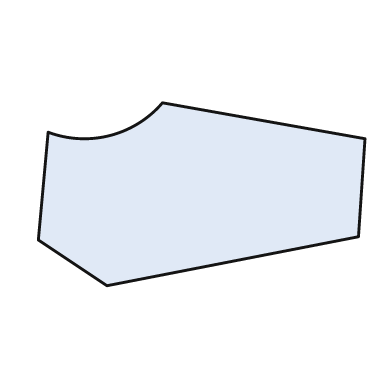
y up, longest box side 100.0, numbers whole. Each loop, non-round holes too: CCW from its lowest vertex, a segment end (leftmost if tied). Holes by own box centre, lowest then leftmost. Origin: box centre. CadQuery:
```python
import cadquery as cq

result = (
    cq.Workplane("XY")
    .moveTo(-29.0, -28.0)
    .lineTo(48.0, -13.0)
    .lineTo(50.0, 17.0)
    .lineTo(-12.0, 28.0)
    .threePointArc((-28.0, 18.0), (-47.0, 19.0))
    .lineTo(-50.0, -14.0)
    .close()
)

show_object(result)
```